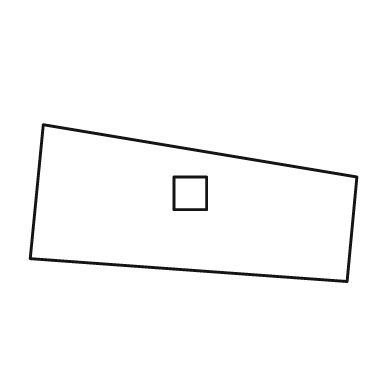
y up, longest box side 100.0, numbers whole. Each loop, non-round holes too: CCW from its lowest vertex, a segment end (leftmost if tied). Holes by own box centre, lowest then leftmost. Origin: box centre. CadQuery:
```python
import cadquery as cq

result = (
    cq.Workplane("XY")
    .moveTo(47.0, -24.0)
    .lineTo(50.0, 8.0)
    .lineTo(-46.0, 24.0)
    .lineTo(-50.0, -17.0)
    .close()
    .moveTo(-6.0, -2.0)
    .lineTo(4.0, -2.0)
    .lineTo(4.0, 8.0)
    .lineTo(-6.0, 8.0)
    .close()
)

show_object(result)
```